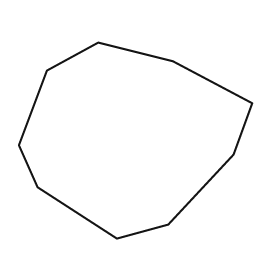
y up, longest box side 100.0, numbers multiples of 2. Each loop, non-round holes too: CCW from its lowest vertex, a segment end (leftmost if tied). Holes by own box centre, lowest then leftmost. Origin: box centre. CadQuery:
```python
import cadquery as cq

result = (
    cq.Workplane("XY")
    .moveTo(-8.0, -42.0)
    .lineTo(14.0, -36.0)
    .lineTo(42.0, -6.0)
    .lineTo(50.0, 16.0)
    .lineTo(16.0, 34.0)
    .lineTo(-16.0, 42.0)
    .lineTo(-38.0, 30.0)
    .lineTo(-50.0, -2.0)
    .lineTo(-42.0, -20.0)
    .close()
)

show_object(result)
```